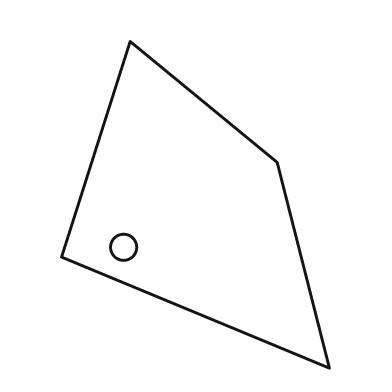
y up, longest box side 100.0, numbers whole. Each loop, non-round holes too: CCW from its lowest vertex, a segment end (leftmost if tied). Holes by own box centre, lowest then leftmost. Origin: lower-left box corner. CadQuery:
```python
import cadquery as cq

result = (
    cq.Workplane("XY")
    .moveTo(82.0, 0.0)
    .lineTo(66.0, 63.0)
    .lineTo(21.0, 100.0)
    .lineTo(0.0, 34.0)
    .close()
    .moveTo(19.0, 37.0)
    .circle(4.0)
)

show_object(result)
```